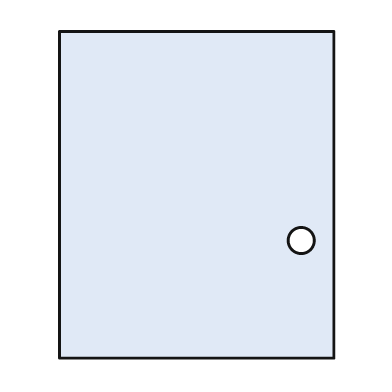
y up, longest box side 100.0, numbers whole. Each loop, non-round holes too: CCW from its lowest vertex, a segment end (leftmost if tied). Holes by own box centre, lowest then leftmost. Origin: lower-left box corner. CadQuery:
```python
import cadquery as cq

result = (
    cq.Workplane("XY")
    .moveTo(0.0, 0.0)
    .lineTo(84.0, 0.0)
    .lineTo(84.0, 100.0)
    .lineTo(0.0, 100.0)
    .close()
    .moveTo(74.0, 36.0)
    .circle(4.0)
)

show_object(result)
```